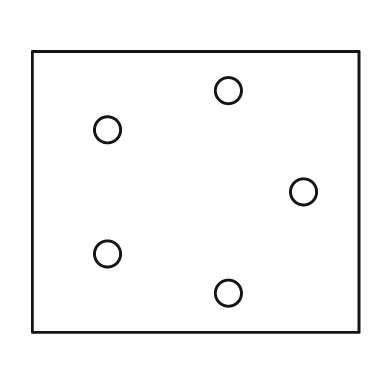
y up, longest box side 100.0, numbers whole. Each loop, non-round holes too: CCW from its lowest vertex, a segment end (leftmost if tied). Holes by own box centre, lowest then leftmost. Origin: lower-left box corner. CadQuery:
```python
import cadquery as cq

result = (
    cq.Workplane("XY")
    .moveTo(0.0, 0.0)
    .lineTo(100.0, 0.0)
    .lineTo(100.0, 86.0)
    .lineTo(0.0, 86.0)
    .close()
    .moveTo(60.0, 12.0)
    .circle(4.0)
    .moveTo(23.0, 24.0)
    .circle(4.0)
    .moveTo(83.0, 43.0)
    .circle(4.0)
    .moveTo(23.0, 62.0)
    .circle(4.0)
    .moveTo(60.0, 74.0)
    .circle(4.0)
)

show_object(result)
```